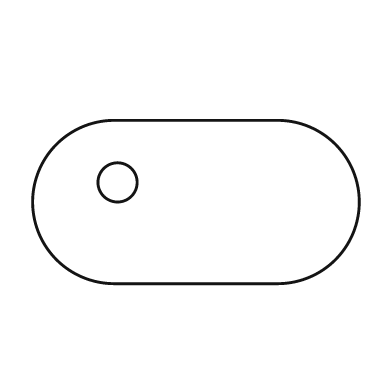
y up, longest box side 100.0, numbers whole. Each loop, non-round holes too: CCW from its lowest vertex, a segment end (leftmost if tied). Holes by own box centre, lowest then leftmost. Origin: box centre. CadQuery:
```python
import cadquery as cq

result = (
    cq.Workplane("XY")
    .moveTo(-25.0, -25.0)
    .lineTo(25.0, -25.0)
    .threePointArc((50.0, 0.0), (25.0, 25.0))
    .lineTo(-25.0, 25.0)
    .threePointArc((-50.0, 0.0), (-25.0, -25.0))
    .close()
    .moveTo(-24.0, 6.0)
    .circle(6.0)
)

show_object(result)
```